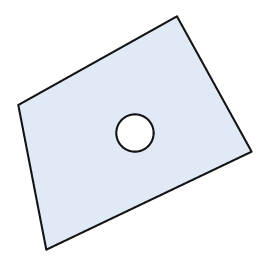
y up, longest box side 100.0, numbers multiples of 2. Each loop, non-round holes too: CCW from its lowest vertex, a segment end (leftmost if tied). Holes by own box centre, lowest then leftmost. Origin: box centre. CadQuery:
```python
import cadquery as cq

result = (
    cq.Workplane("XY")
    .moveTo(-38.0, -50.0)
    .lineTo(50.0, -8.0)
    .lineTo(18.0, 50.0)
    .lineTo(-50.0, 12.0)
    .close()
    .moveTo(0.0, 0.0)
    .circle(8.0)
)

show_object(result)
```